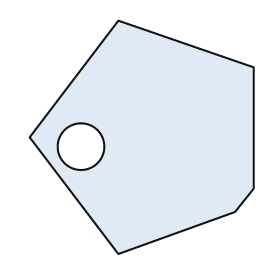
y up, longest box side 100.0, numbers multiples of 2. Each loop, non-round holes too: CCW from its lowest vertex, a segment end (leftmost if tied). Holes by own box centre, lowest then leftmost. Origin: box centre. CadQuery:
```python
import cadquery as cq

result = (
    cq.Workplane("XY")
    .moveTo(-10.0, -50.0)
    .lineTo(40.0, -32.0)
    .lineTo(48.0, -22.0)
    .lineTo(48.0, 30.0)
    .lineTo(-10.0, 50.0)
    .lineTo(-48.0, 0.0)
    .close()
    .moveTo(-26.0, -4.0)
    .circle(10.0)
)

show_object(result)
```